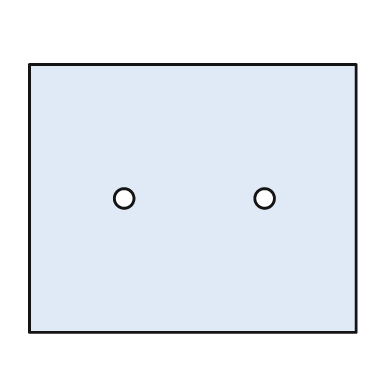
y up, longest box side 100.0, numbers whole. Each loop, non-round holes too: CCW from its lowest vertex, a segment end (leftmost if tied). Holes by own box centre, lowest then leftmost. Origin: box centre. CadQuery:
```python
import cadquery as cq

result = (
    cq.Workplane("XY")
    .moveTo(-50.0, -41.0)
    .lineTo(50.0, -41.0)
    .lineTo(50.0, 41.0)
    .lineTo(-50.0, 41.0)
    .close()
    .moveTo(-21.0, 0.0)
    .circle(3.0)
    .moveTo(22.0, 0.0)
    .circle(3.0)
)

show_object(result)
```